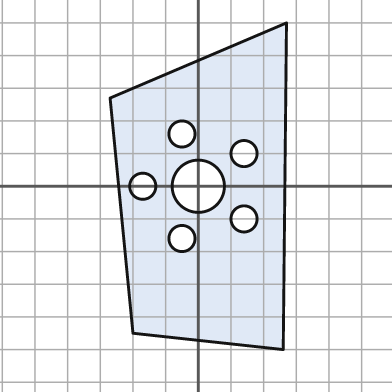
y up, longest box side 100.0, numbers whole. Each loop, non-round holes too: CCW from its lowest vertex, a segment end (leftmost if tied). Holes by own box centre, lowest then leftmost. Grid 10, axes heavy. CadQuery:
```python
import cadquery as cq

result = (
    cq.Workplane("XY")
    .moveTo(26.0, -50.0)
    .lineTo(27.0, 50.0)
    .lineTo(-27.0, 27.0)
    .lineTo(-20.0, -45.0)
    .close()
    .moveTo(-5.0, -16.0)
    .circle(4.0)
    .moveTo(14.0, -10.0)
    .circle(4.0)
    .moveTo(-17.0, 0.0)
    .circle(4.0)
    .moveTo(0.0, 0.0)
    .circle(8.0)
    .moveTo(14.0, 10.0)
    .circle(4.0)
    .moveTo(-5.0, 16.0)
    .circle(4.0)
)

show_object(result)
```